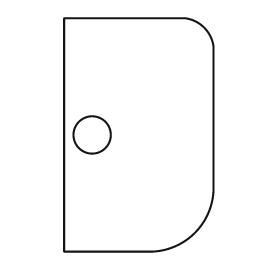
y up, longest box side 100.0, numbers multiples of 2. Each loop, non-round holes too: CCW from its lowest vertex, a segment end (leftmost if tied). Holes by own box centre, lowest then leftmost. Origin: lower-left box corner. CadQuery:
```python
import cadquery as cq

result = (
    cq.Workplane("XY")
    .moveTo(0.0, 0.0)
    .lineTo(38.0, 0.0)
    .threePointArc((56.0, 8.0), (64.0, 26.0))
    .lineTo(64.0, 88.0)
    .threePointArc((60.0, 96.0), (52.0, 100.0))
    .lineTo(0.0, 100.0)
    .close()
    .moveTo(12.0, 50.0)
    .circle(8.0)
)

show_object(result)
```